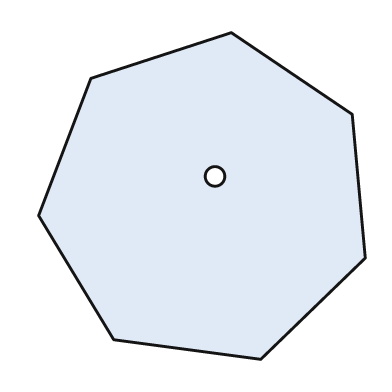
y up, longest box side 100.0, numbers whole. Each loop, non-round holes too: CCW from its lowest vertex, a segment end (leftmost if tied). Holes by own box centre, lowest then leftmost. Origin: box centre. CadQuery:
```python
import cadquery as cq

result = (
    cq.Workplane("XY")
    .moveTo(18.0, -50.0)
    .lineTo(50.0, -19.0)
    .lineTo(46.0, 25.0)
    .lineTo(9.0, 50.0)
    .lineTo(-34.0, 36.0)
    .lineTo(-50.0, -6.0)
    .lineTo(-27.0, -44.0)
    .close()
    .moveTo(4.0, 6.0)
    .circle(3.0)
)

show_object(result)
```